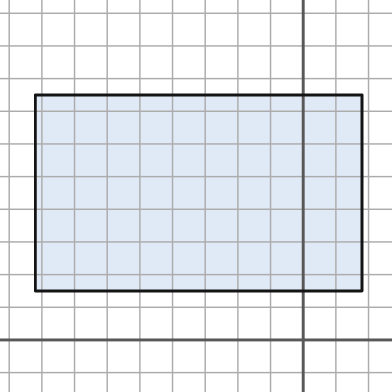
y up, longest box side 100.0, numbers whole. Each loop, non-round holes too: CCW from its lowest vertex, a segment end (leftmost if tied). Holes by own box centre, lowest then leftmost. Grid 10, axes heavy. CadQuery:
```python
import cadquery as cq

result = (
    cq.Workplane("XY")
    .moveTo(-82.0, 15.0)
    .lineTo(18.0, 15.0)
    .lineTo(18.0, 75.0)
    .lineTo(-82.0, 75.0)
    .close()
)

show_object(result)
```